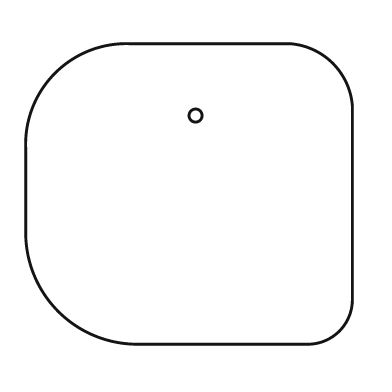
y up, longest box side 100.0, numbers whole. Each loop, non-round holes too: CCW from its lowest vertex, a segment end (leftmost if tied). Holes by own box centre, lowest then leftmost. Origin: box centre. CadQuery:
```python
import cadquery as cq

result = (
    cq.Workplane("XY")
    .moveTo(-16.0, -46.0)
    .lineTo(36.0, -46.0)
    .threePointArc((46.0, -42.0), (50.0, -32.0))
    .lineTo(50.0, 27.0)
    .threePointArc((44.0, 40.0), (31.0, 46.0))
    .lineTo(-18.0, 46.0)
    .threePointArc((-41.0, 37.0), (-50.0, 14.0))
    .lineTo(-50.0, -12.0)
    .threePointArc((-40.0, -36.0), (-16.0, -46.0))
    .close()
    .moveTo(2.0, 24.0)
    .circle(2.0)
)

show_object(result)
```